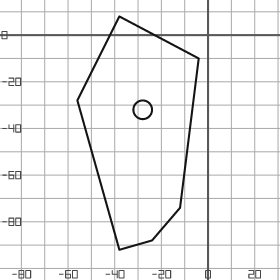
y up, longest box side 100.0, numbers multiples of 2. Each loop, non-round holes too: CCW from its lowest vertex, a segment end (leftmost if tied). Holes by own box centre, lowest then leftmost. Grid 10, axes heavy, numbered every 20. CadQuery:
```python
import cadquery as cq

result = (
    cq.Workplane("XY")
    .moveTo(-38.0, -92.0)
    .lineTo(-24.0, -88.0)
    .lineTo(-12.0, -74.0)
    .lineTo(-4.0, -10.0)
    .lineTo(-38.0, 8.0)
    .lineTo(-56.0, -28.0)
    .close()
    .moveTo(-28.0, -32.0)
    .circle(4.0)
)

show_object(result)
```